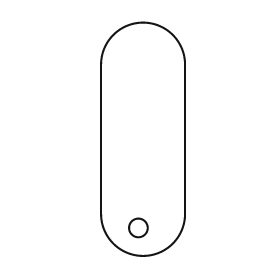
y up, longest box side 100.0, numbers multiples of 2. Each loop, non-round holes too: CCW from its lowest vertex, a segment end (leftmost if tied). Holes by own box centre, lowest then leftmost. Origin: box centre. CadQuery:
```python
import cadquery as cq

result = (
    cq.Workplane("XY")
    .moveTo(-18.0, -32.0)
    .threePointArc((0.0, -50.0), (18.0, -32.0))
    .lineTo(18.0, 32.0)
    .threePointArc((0.0, 50.0), (-18.0, 32.0))
    .close()
    .moveTo(-2.0, -38.0)
    .circle(4.0)
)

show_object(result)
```